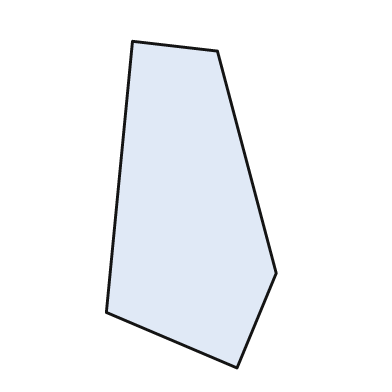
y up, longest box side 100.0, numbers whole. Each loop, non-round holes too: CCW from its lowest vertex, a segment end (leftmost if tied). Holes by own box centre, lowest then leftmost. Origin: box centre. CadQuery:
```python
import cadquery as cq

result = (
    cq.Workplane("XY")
    .moveTo(14.0, -50.0)
    .lineTo(26.0, -21.0)
    .lineTo(8.0, 47.0)
    .lineTo(-18.0, 50.0)
    .lineTo(-26.0, -33.0)
    .close()
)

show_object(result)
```